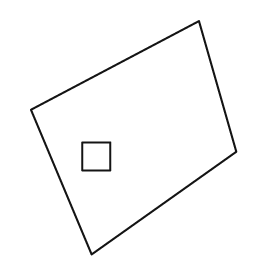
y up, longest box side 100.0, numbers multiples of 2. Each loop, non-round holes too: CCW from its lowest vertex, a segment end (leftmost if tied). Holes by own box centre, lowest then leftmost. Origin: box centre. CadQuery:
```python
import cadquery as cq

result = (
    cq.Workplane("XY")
    .moveTo(-18.0, -50.0)
    .lineTo(44.0, -6.0)
    .lineTo(28.0, 50.0)
    .lineTo(-44.0, 12.0)
    .close()
    .moveTo(-22.0, -14.0)
    .lineTo(-10.0, -14.0)
    .lineTo(-10.0, -2.0)
    .lineTo(-22.0, -2.0)
    .close()
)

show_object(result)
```